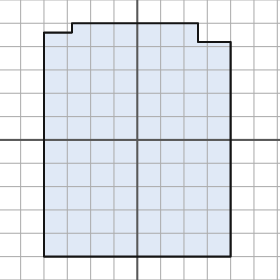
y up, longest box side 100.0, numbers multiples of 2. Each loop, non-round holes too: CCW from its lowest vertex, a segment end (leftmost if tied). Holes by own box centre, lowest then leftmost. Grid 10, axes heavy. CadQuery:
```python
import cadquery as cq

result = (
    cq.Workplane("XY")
    .moveTo(-40.0, -50.0)
    .lineTo(40.0, -50.0)
    .lineTo(40.0, 42.0)
    .lineTo(26.0, 42.0)
    .lineTo(26.0, 50.0)
    .lineTo(-28.0, 50.0)
    .lineTo(-28.0, 46.0)
    .lineTo(-40.0, 46.0)
    .close()
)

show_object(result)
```